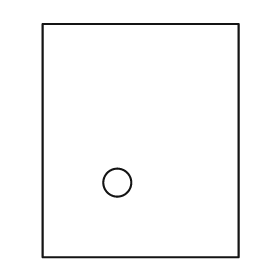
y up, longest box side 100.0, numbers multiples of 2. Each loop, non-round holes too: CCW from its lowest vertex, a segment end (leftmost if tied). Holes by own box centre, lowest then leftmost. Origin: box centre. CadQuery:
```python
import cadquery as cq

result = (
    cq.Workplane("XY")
    .moveTo(-42.0, -50.0)
    .lineTo(42.0, -50.0)
    .lineTo(42.0, 50.0)
    .lineTo(-42.0, 50.0)
    .close()
    .moveTo(-10.0, -18.0)
    .circle(6.0)
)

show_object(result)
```